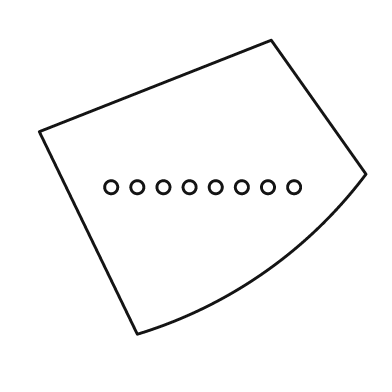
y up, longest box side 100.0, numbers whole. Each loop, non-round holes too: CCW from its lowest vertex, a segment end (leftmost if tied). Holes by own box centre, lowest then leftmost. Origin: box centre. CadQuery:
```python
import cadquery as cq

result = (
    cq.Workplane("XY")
    .moveTo(-20.0, -45.0)
    .threePointArc((19.0, -26.0), (50.0, 4.0))
    .lineTo(21.0, 45.0)
    .lineTo(-50.0, 17.0)
    .close()
    .moveTo(-28.0, 0.0)
    .circle(2.0)
    .moveTo(-20.0, 0.0)
    .circle(2.0)
    .moveTo(-12.0, 0.0)
    .circle(2.0)
    .moveTo(-4.0, 0.0)
    .circle(2.0)
    .moveTo(4.0, 0.0)
    .circle(2.0)
    .moveTo(12.0, 0.0)
    .circle(2.0)
    .moveTo(20.0, 0.0)
    .circle(2.0)
    .moveTo(28.0, 0.0)
    .circle(2.0)
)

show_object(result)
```